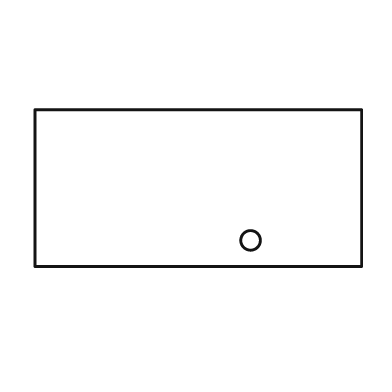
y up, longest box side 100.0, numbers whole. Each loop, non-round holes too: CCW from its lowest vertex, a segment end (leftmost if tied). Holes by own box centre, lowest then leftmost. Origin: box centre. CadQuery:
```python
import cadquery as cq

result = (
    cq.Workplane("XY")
    .moveTo(-50.0, -24.0)
    .lineTo(50.0, -24.0)
    .lineTo(50.0, 24.0)
    .lineTo(-50.0, 24.0)
    .close()
    .moveTo(16.0, -16.0)
    .circle(3.0)
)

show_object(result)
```